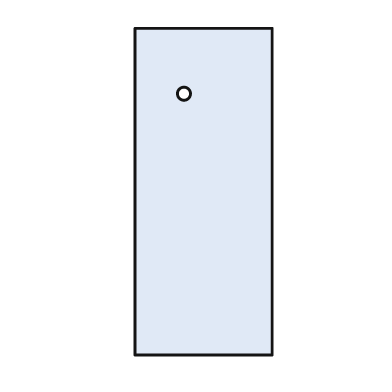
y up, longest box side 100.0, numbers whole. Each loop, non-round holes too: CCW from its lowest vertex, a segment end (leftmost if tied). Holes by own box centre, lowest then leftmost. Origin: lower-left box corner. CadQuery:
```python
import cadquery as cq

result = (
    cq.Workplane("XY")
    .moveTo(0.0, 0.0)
    .lineTo(42.0, 0.0)
    .lineTo(42.0, 100.0)
    .lineTo(0.0, 100.0)
    .close()
    .moveTo(15.0, 80.0)
    .circle(2.0)
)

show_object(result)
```